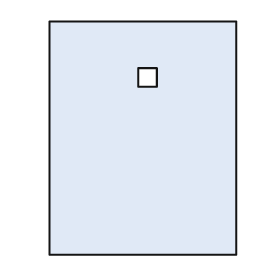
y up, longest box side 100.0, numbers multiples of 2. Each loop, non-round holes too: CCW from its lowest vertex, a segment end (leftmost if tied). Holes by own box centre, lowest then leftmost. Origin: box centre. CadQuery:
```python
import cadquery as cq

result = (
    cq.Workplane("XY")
    .moveTo(-40.0, -50.0)
    .lineTo(40.0, -50.0)
    .lineTo(40.0, 50.0)
    .lineTo(-40.0, 50.0)
    .close()
    .moveTo(-2.0, 22.0)
    .lineTo(6.0, 22.0)
    .lineTo(6.0, 30.0)
    .lineTo(-2.0, 30.0)
    .close()
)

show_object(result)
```